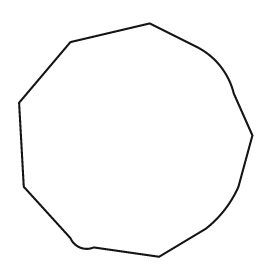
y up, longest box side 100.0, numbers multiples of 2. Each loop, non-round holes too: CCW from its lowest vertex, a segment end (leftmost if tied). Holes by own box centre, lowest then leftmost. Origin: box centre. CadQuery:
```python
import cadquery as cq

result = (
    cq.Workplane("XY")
    .moveTo(10.0, -50.0)
    .lineTo(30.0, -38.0)
    .threePointArc((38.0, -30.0), (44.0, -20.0))
    .lineTo(50.0, 2.0)
    .lineTo(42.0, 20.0)
    .threePointArc((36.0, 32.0), (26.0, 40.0))
    .lineTo(6.0, 50.0)
    .lineTo(-28.0, 42.0)
    .lineTo(-50.0, 16.0)
    .lineTo(-48.0, -20.0)
    .lineTo(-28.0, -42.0)
    .threePointArc((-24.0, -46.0), (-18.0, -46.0))
    .close()
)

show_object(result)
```